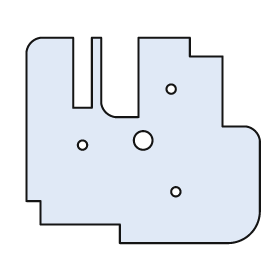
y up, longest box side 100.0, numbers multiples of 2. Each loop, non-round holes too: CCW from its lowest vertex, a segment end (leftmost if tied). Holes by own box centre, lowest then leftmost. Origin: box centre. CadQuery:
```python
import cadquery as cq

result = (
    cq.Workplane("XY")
    .moveTo(-10.0, -44.0)
    .lineTo(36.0, -44.0)
    .threePointArc((46.0, -40.0), (50.0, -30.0))
    .lineTo(50.0, 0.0)
    .threePointArc((48.0, 4.0), (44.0, 6.0))
    .lineTo(34.0, 6.0)
    .lineTo(34.0, 36.0)
    .lineTo(20.0, 36.0)
    .lineTo(20.0, 44.0)
    .lineTo(-2.0, 44.0)
    .lineTo(-2.0, 10.0)
    .lineTo(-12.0, 10.0)
    .threePointArc((-16.0, 12.0), (-18.0, 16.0))
    .lineTo(-18.0, 44.0)
    .lineTo(-22.0, 44.0)
    .lineTo(-22.0, 14.0)
    .lineTo(-30.0, 14.0)
    .lineTo(-30.0, 44.0)
    .lineTo(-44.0, 44.0)
    .threePointArc((-48.0, 42.0), (-50.0, 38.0))
    .lineTo(-50.0, -26.0)
    .lineTo(-44.0, -26.0)
    .lineTo(-44.0, -36.0)
    .lineTo(-10.0, -36.0)
    .close()
    .moveTo(14.0, -22.0)
    .circle(2.0)
    .moveTo(-26.0, -2.0)
    .circle(2.0)
    .moveTo(0.0, 0.0)
    .circle(4.0)
    .moveTo(12.0, 22.0)
    .circle(2.0)
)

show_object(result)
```